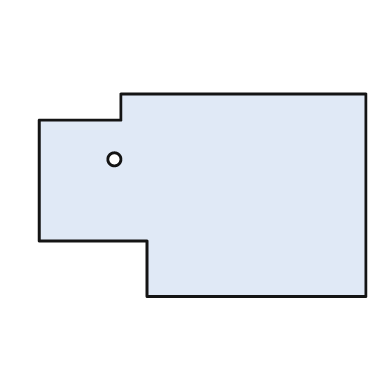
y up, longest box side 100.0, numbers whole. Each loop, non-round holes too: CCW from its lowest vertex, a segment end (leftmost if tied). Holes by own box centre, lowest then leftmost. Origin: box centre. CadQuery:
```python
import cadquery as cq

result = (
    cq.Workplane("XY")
    .moveTo(-17.0, -31.0)
    .lineTo(50.0, -31.0)
    .lineTo(50.0, 31.0)
    .lineTo(-25.0, 31.0)
    .lineTo(-25.0, 23.0)
    .lineTo(-50.0, 23.0)
    .lineTo(-50.0, -14.0)
    .lineTo(-17.0, -14.0)
    .close()
    .moveTo(-27.0, 11.0)
    .circle(2.0)
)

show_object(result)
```